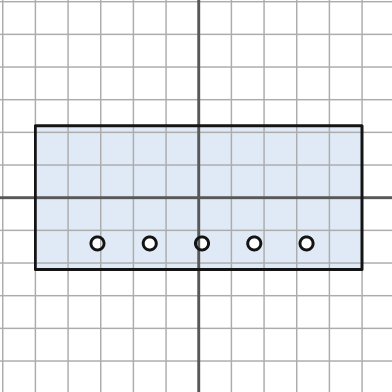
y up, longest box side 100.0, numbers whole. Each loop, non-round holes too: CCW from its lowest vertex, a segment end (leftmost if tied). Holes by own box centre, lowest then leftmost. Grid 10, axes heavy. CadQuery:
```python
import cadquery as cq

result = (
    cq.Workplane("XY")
    .moveTo(-50.0, -22.0)
    .lineTo(50.0, -22.0)
    .lineTo(50.0, 22.0)
    .lineTo(-50.0, 22.0)
    .close()
    .moveTo(-31.0, -14.0)
    .circle(2.0)
    .moveTo(-15.0, -14.0)
    .circle(2.0)
    .moveTo(1.0, -14.0)
    .circle(2.0)
    .moveTo(17.0, -14.0)
    .circle(2.0)
    .moveTo(33.0, -14.0)
    .circle(2.0)
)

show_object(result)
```